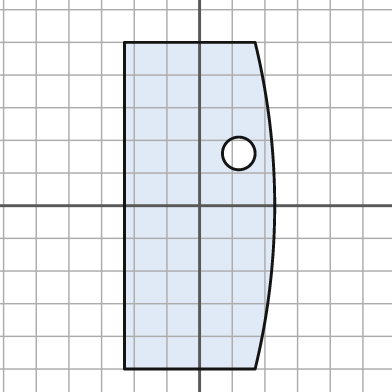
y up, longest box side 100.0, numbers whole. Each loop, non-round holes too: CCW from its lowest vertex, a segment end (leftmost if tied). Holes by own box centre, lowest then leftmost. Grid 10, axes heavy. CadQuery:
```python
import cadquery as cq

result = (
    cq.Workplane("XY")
    .moveTo(-23.0, -50.0)
    .lineTo(17.0, -50.0)
    .threePointArc((23.0, 0.0), (17.0, 50.0))
    .lineTo(-23.0, 50.0)
    .close()
    .moveTo(12.0, 16.0)
    .circle(5.0)
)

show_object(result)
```